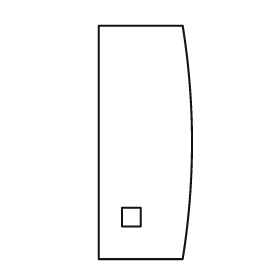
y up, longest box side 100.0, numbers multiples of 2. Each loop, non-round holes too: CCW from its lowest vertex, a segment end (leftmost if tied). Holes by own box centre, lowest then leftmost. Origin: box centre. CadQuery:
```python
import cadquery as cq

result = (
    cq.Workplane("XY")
    .moveTo(-20.0, -50.0)
    .lineTo(16.0, -50.0)
    .threePointArc((20.0, 0.0), (16.0, 50.0))
    .lineTo(-20.0, 50.0)
    .close()
    .moveTo(-10.0, -36.0)
    .lineTo(-2.0, -36.0)
    .lineTo(-2.0, -28.0)
    .lineTo(-10.0, -28.0)
    .close()
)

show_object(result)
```